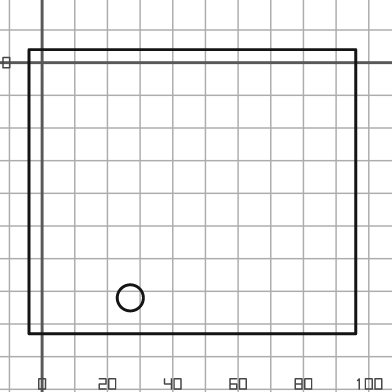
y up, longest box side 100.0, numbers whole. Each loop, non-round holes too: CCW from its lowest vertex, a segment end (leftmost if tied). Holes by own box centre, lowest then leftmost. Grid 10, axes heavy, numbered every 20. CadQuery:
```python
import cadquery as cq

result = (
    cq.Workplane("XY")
    .moveTo(-4.0, -83.0)
    .lineTo(96.0, -83.0)
    .lineTo(96.0, 4.0)
    .lineTo(-4.0, 4.0)
    .close()
    .moveTo(27.0, -72.0)
    .circle(4.0)
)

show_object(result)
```